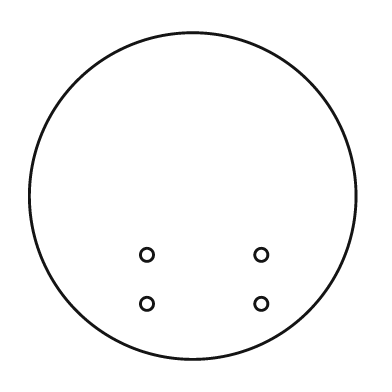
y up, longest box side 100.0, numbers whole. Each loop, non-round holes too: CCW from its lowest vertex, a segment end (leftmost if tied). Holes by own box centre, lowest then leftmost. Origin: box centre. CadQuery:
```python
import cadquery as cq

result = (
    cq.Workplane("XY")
    .moveTo(0.0, 0.0)
    .circle(50.0)
    .moveTo(-14.0, -33.0)
    .circle(2.0)
    .moveTo(21.0, -33.0)
    .circle(2.0)
    .moveTo(-14.0, -18.0)
    .circle(2.0)
    .moveTo(21.0, -18.0)
    .circle(2.0)
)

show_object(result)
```